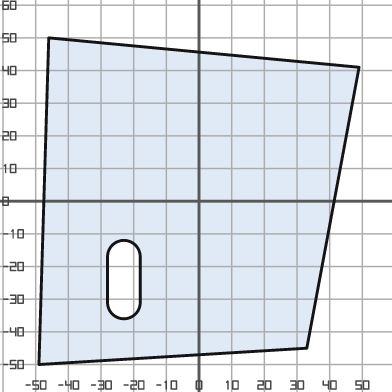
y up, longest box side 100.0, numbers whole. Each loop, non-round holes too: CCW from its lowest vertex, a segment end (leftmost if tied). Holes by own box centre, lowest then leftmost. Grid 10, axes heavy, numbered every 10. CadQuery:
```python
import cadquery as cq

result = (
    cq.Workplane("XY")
    .moveTo(-49.0, -50.0)
    .lineTo(33.0, -45.0)
    .lineTo(49.0, 41.0)
    .lineTo(-46.0, 50.0)
    .close()
    .moveTo(-28.0, -31.0)
    .threePointArc((-23.0, -36.0), (-18.0, -31.0))
    .lineTo(-18.0, -17.0)
    .threePointArc((-23.0, -12.0), (-28.0, -17.0))
    .close()
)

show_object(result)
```